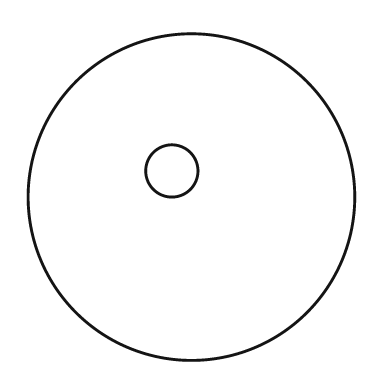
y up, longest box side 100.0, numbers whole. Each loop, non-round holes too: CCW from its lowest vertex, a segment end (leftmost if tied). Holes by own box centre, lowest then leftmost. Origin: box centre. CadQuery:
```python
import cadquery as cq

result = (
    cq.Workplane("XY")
    .moveTo(0.0, 0.0)
    .circle(50.0)
    .moveTo(-6.0, 8.0)
    .circle(8.0)
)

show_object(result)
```